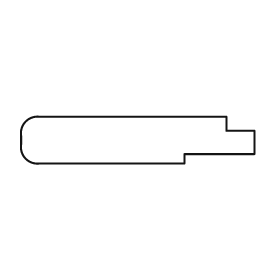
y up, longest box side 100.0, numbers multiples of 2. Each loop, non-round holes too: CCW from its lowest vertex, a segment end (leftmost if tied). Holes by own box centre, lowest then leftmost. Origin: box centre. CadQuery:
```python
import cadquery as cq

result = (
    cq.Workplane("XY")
    .moveTo(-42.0, -10.0)
    .lineTo(20.0, -10.0)
    .lineTo(20.0, -6.0)
    .lineTo(50.0, -6.0)
    .lineTo(50.0, 4.0)
    .lineTo(38.0, 4.0)
    .lineTo(38.0, 10.0)
    .lineTo(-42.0, 10.0)
    .threePointArc((-48.0, 8.0), (-50.0, 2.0))
    .lineTo(-50.0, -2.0)
    .threePointArc((-48.0, -8.0), (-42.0, -10.0))
    .close()
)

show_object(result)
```